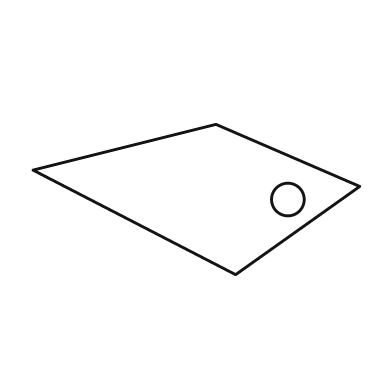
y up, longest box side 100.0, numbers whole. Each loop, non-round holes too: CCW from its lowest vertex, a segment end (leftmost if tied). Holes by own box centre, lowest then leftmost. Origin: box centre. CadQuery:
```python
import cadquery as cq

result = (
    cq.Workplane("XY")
    .moveTo(12.0, -23.0)
    .lineTo(50.0, 4.0)
    .lineTo(6.0, 23.0)
    .lineTo(-50.0, 9.0)
    .close()
    .moveTo(28.0, 0.0)
    .circle(5.0)
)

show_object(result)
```